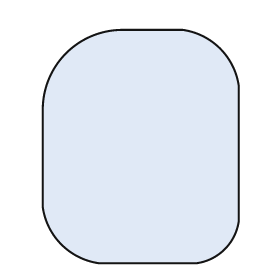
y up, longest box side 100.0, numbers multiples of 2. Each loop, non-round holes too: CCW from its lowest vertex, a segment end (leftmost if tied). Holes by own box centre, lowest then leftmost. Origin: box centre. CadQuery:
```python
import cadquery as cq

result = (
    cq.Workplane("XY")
    .moveTo(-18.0, -50.0)
    .lineTo(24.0, -50.0)
    .threePointArc((36.0, -44.0), (42.0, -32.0))
    .lineTo(42.0, 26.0)
    .threePointArc((34.0, 42.0), (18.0, 50.0))
    .lineTo(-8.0, 50.0)
    .threePointArc((-32.0, 40.0), (-42.0, 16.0))
    .lineTo(-42.0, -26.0)
    .threePointArc((-34.0, -42.0), (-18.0, -50.0))
    .close()
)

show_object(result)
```